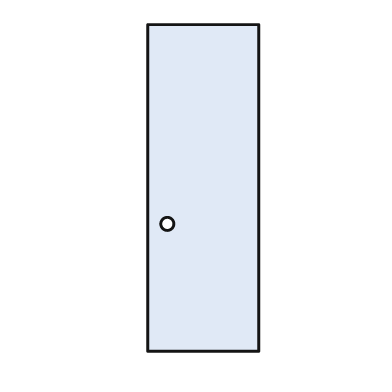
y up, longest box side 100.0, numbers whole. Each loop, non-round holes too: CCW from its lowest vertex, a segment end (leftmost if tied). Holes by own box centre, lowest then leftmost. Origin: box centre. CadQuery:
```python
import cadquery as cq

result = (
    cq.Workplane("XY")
    .moveTo(-17.0, -50.0)
    .lineTo(17.0, -50.0)
    .lineTo(17.0, 50.0)
    .lineTo(-17.0, 50.0)
    .close()
    .moveTo(-11.0, -11.0)
    .circle(2.0)
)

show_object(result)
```